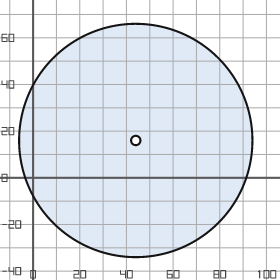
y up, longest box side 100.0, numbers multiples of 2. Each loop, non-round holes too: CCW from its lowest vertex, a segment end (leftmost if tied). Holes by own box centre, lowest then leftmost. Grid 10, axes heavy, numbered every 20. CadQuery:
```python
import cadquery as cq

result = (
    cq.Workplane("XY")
    .moveTo(44.0, 16.0)
    .circle(50.0)
    .moveTo(44.0, 16.0)
    .circle(2.0)
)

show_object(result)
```